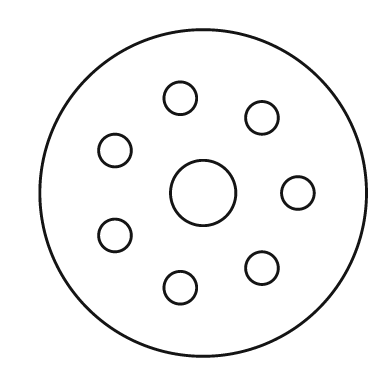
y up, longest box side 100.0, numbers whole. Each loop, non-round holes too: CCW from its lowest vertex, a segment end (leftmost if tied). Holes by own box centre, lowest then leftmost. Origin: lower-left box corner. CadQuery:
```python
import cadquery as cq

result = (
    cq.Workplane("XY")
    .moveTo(50.0, 50.0)
    .circle(50.0)
    .moveTo(43.0, 21.0)
    .circle(5.0)
    .moveTo(68.0, 27.0)
    .circle(5.0)
    .moveTo(23.0, 37.0)
    .circle(5.0)
    .moveTo(50.0, 50.0)
    .circle(10.0)
    .moveTo(79.0, 50.0)
    .circle(5.0)
    .moveTo(23.0, 63.0)
    .circle(5.0)
    .moveTo(68.0, 73.0)
    .circle(5.0)
    .moveTo(43.0, 79.0)
    .circle(5.0)
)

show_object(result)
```